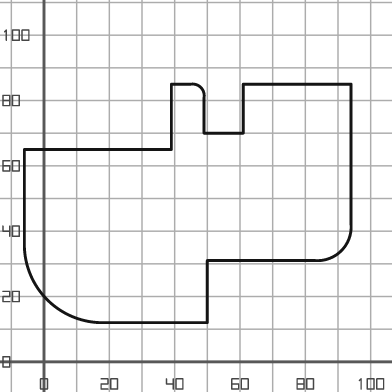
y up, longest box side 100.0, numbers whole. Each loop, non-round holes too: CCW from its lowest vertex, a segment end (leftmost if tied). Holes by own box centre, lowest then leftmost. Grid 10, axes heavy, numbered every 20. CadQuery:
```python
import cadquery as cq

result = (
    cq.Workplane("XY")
    .moveTo(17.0, 12.0)
    .lineTo(50.0, 12.0)
    .lineTo(50.0, 31.0)
    .lineTo(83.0, 31.0)
    .threePointArc((91.0, 34.0), (94.0, 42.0))
    .lineTo(94.0, 85.0)
    .lineTo(61.0, 85.0)
    .lineTo(61.0, 70.0)
    .lineTo(49.0, 70.0)
    .lineTo(49.0, 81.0)
    .threePointArc((48.0, 84.0), (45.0, 85.0))
    .lineTo(39.0, 85.0)
    .lineTo(39.0, 65.0)
    .lineTo(-6.0, 65.0)
    .lineTo(-6.0, 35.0)
    .threePointArc((1.0, 19.0), (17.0, 12.0))
    .close()
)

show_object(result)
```